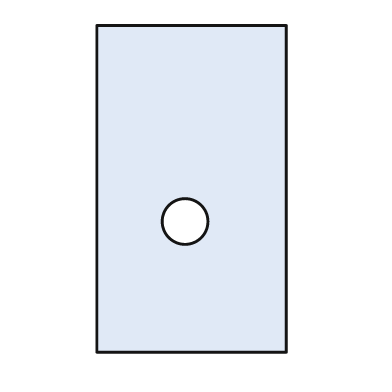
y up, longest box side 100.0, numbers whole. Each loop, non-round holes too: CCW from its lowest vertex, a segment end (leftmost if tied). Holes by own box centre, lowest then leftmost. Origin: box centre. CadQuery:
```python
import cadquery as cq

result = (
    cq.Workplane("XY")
    .moveTo(-29.0, -50.0)
    .lineTo(29.0, -50.0)
    .lineTo(29.0, 50.0)
    .lineTo(-29.0, 50.0)
    .close()
    .moveTo(-2.0, -10.0)
    .circle(7.0)
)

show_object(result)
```